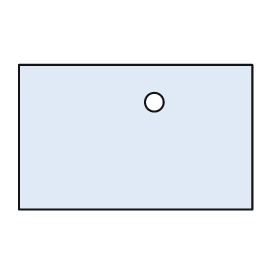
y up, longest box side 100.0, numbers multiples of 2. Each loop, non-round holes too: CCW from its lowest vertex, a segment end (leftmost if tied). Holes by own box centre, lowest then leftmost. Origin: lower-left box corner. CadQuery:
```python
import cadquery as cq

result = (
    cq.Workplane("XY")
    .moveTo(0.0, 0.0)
    .lineTo(100.0, 0.0)
    .lineTo(100.0, 62.0)
    .lineTo(0.0, 62.0)
    .close()
    .moveTo(58.0, 46.0)
    .circle(4.0)
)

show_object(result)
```